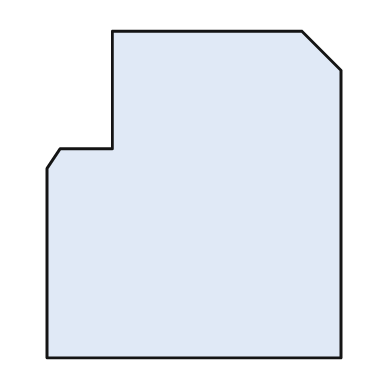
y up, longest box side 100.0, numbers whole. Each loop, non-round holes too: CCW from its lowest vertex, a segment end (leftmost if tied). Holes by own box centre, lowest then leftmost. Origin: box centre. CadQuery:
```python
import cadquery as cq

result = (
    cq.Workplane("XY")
    .moveTo(-45.0, -50.0)
    .lineTo(45.0, -50.0)
    .lineTo(45.0, 38.0)
    .lineTo(33.0, 50.0)
    .lineTo(-25.0, 50.0)
    .lineTo(-25.0, 14.0)
    .lineTo(-41.0, 14.0)
    .lineTo(-45.0, 8.0)
    .close()
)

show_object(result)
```